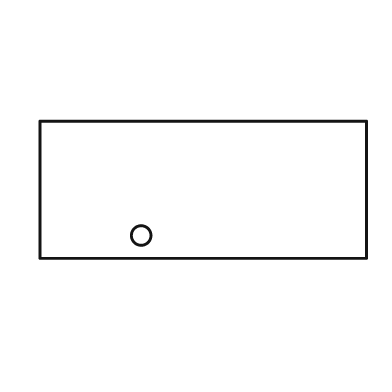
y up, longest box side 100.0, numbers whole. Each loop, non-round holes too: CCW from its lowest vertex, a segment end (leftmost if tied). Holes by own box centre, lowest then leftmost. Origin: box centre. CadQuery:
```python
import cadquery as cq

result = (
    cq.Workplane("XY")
    .moveTo(-50.0, -21.0)
    .lineTo(50.0, -21.0)
    .lineTo(50.0, 21.0)
    .lineTo(-50.0, 21.0)
    .close()
    .moveTo(-19.0, -14.0)
    .circle(3.0)
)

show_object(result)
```